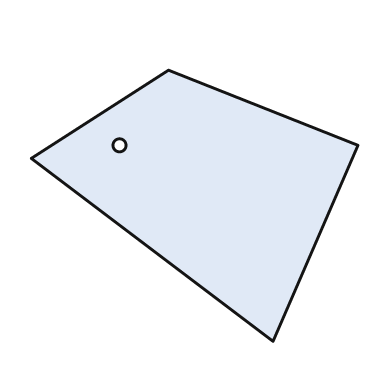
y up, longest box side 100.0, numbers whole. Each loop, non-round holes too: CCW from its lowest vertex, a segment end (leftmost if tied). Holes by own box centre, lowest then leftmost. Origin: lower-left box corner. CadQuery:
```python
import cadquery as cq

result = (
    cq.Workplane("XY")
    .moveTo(74.0, 0.0)
    .lineTo(100.0, 60.0)
    .lineTo(42.0, 83.0)
    .lineTo(0.0, 56.0)
    .close()
    .moveTo(27.0, 60.0)
    .circle(2.0)
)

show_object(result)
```